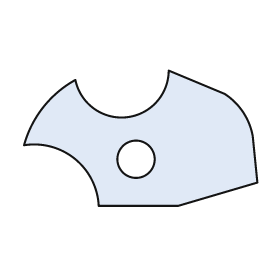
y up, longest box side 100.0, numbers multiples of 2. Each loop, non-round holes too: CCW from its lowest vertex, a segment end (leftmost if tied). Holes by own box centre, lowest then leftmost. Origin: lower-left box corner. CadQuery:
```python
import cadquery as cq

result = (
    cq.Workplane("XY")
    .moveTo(32.0, 0.0)
    .lineTo(66.0, 0.0)
    .lineTo(100.0, 10.0)
    .lineTo(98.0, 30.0)
    .threePointArc((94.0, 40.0), (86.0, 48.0))
    .lineTo(62.0, 58.0)
    .threePointArc((44.0, 38.0), (22.0, 54.0))
    .threePointArc((8.0, 42.0), (0.0, 26.0))
    .threePointArc((22.0, 20.0), (32.0, 0.0))
    .close()
    .moveTo(48.0, 20.0)
    .circle(8.0)
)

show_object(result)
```